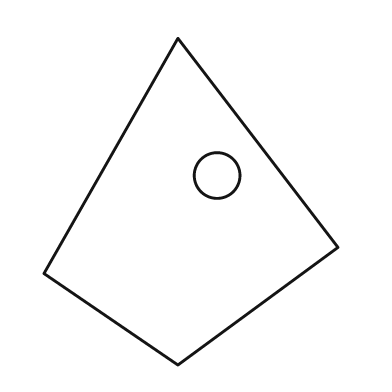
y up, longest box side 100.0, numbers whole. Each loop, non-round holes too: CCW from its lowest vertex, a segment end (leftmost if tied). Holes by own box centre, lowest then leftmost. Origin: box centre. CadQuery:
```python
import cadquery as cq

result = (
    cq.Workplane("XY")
    .moveTo(-4.0, -50.0)
    .lineTo(45.0, -14.0)
    .lineTo(-4.0, 50.0)
    .lineTo(-45.0, -22.0)
    .close()
    .moveTo(8.0, 8.0)
    .circle(7.0)
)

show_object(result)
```